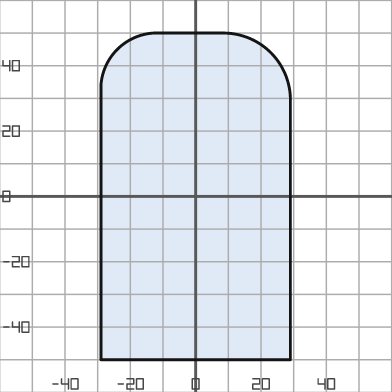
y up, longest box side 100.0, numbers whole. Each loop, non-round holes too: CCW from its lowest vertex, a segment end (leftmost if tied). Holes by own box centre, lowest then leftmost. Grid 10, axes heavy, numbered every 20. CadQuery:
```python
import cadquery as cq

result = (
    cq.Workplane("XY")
    .moveTo(-29.0, -50.0)
    .lineTo(29.0, -50.0)
    .lineTo(29.0, 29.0)
    .threePointArc((23.0, 44.0), (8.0, 50.0))
    .lineTo(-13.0, 50.0)
    .threePointArc((-24.0, 45.0), (-29.0, 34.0))
    .close()
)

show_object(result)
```